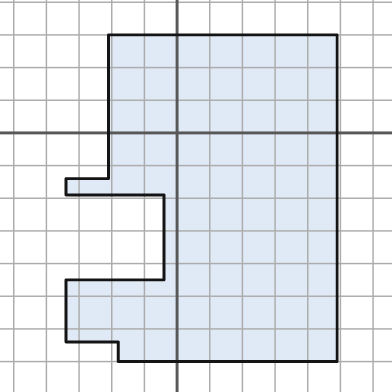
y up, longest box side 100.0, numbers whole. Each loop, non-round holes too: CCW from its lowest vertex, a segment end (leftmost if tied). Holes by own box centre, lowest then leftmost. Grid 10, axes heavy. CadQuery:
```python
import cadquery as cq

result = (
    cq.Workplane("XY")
    .moveTo(-18.0, -70.0)
    .lineTo(49.0, -70.0)
    .lineTo(49.0, 30.0)
    .lineTo(-21.0, 30.0)
    .lineTo(-21.0, -14.0)
    .lineTo(-34.0, -14.0)
    .lineTo(-34.0, -19.0)
    .lineTo(-4.0, -19.0)
    .lineTo(-4.0, -45.0)
    .lineTo(-34.0, -45.0)
    .lineTo(-34.0, -64.0)
    .lineTo(-18.0, -64.0)
    .close()
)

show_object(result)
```